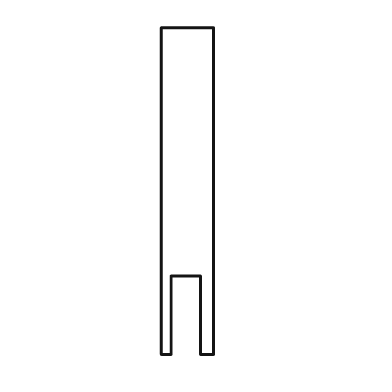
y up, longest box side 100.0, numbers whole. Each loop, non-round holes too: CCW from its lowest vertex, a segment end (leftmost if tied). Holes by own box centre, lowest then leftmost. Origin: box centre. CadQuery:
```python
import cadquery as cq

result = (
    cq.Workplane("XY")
    .moveTo(-8.0, -50.0)
    .lineTo(-5.0, -50.0)
    .lineTo(-5.0, -26.0)
    .lineTo(4.0, -26.0)
    .lineTo(4.0, -50.0)
    .lineTo(8.0, -50.0)
    .lineTo(8.0, 50.0)
    .lineTo(-8.0, 50.0)
    .close()
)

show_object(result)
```